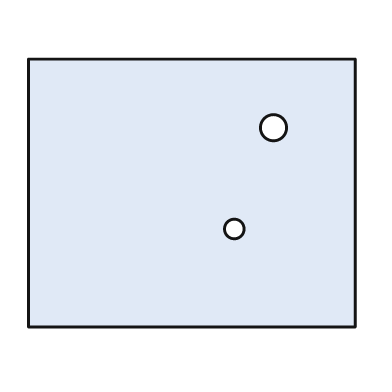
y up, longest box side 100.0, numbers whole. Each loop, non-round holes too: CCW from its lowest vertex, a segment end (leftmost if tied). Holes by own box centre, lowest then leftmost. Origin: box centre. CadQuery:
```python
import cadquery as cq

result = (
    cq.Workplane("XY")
    .moveTo(-50.0, -41.0)
    .lineTo(50.0, -41.0)
    .lineTo(50.0, 41.0)
    .lineTo(-50.0, 41.0)
    .close()
    .moveTo(13.0, -11.0)
    .circle(3.0)
    .moveTo(25.0, 20.0)
    .circle(4.0)
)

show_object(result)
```